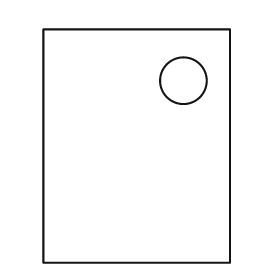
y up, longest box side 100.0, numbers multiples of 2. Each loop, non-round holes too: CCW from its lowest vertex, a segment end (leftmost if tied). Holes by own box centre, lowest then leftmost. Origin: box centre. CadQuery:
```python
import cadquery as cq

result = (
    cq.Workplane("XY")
    .moveTo(-40.0, -50.0)
    .lineTo(40.0, -50.0)
    .lineTo(40.0, 50.0)
    .lineTo(-40.0, 50.0)
    .close()
    .moveTo(20.0, 28.0)
    .circle(10.0)
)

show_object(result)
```